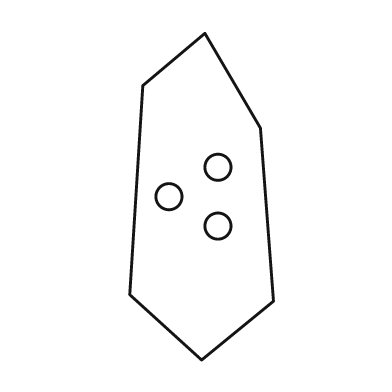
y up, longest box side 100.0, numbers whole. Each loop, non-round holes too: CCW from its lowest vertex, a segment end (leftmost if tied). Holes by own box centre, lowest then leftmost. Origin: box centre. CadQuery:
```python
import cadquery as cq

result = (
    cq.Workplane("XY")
    .moveTo(0.0, -50.0)
    .lineTo(22.0, -32.0)
    .lineTo(18.0, 21.0)
    .lineTo(1.0, 50.0)
    .lineTo(-18.0, 34.0)
    .lineTo(-22.0, -30.0)
    .close()
    .moveTo(5.0, -9.0)
    .circle(4.0)
    .moveTo(-10.0, 0.0)
    .circle(4.0)
    .moveTo(5.0, 9.0)
    .circle(4.0)
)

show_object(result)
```